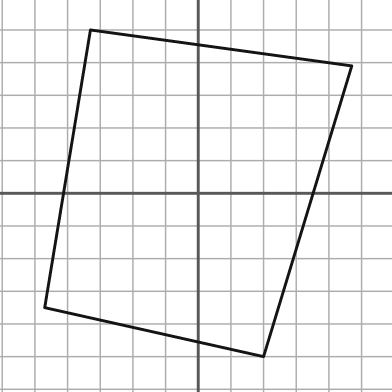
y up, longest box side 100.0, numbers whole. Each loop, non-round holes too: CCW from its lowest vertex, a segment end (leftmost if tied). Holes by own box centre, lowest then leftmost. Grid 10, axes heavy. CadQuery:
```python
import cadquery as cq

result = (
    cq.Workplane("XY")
    .moveTo(20.0, -50.0)
    .lineTo(47.0, 39.0)
    .lineTo(-33.0, 50.0)
    .lineTo(-47.0, -35.0)
    .close()
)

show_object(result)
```